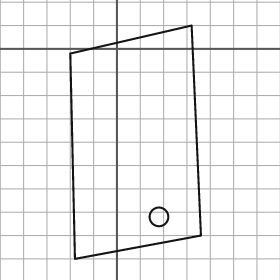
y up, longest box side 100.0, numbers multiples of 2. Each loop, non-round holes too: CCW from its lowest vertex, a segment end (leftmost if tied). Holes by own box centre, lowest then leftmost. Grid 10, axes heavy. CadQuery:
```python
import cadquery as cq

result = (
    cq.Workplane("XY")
    .moveTo(-18.0, -90.0)
    .lineTo(36.0, -80.0)
    .lineTo(32.0, 10.0)
    .lineTo(-20.0, -2.0)
    .close()
    .moveTo(18.0, -72.0)
    .circle(4.0)
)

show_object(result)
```